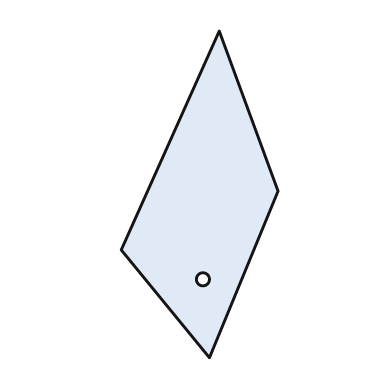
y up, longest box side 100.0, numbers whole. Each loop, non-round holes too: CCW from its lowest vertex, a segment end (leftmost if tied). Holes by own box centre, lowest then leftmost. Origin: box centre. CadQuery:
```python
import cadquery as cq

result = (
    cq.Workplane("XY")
    .moveTo(3.0, -50.0)
    .lineTo(24.0, 1.0)
    .lineTo(6.0, 50.0)
    .lineTo(-24.0, -17.0)
    .close()
    .moveTo(1.0, -26.0)
    .circle(2.0)
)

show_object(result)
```